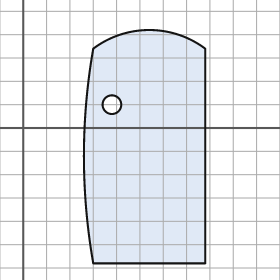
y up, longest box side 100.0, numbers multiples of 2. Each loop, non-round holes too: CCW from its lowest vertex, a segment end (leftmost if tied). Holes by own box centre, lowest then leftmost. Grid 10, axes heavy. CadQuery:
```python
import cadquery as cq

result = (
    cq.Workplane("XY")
    .moveTo(30.0, -58.0)
    .lineTo(78.0, -58.0)
    .lineTo(78.0, 34.0)
    .threePointArc((54.0, 42.0), (30.0, 34.0))
    .threePointArc((26.0, -12.0), (30.0, -58.0))
    .close()
    .moveTo(38.0, 10.0)
    .circle(4.0)
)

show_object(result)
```